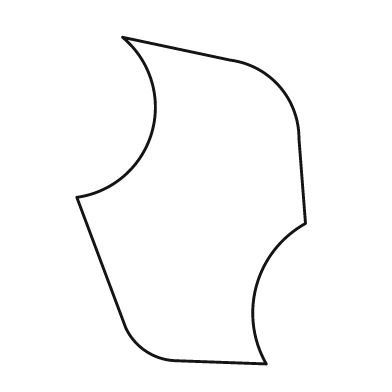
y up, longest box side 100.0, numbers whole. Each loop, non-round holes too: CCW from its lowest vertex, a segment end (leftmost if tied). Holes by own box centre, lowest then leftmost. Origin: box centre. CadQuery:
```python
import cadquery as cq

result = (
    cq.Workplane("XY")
    .moveTo(23.0, -50.0)
    .threePointArc((20.0, -26.0), (35.0, -7.0))
    .lineTo(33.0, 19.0)
    .threePointArc((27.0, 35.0), (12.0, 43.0))
    .lineTo(-21.0, 50.0)
    .threePointArc((-12.0, 21.0), (-35.0, 1.0))
    .lineTo(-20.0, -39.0)
    .threePointArc((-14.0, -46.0), (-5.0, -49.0))
    .close()
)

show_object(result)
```